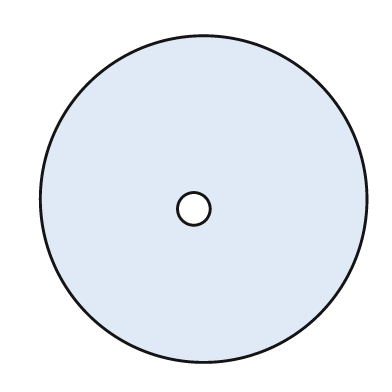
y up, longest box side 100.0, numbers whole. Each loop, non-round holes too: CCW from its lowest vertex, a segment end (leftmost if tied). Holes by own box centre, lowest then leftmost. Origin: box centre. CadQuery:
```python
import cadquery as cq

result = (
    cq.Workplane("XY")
    .moveTo(0.0, 0.0)
    .circle(50.0)
    .moveTo(-3.0, -3.0)
    .circle(5.0)
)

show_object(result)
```